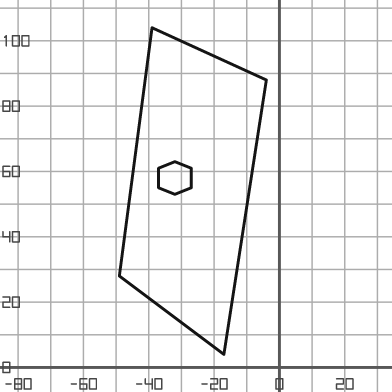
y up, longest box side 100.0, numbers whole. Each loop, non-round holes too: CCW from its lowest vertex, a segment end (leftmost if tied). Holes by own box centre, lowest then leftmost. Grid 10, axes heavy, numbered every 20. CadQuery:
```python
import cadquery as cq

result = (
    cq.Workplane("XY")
    .moveTo(-17.0, 4.0)
    .lineTo(-4.0, 88.0)
    .lineTo(-39.0, 104.0)
    .lineTo(-49.0, 28.0)
    .close()
    .moveTo(-32.0, 53.0)
    .lineTo(-27.0, 55.0)
    .lineTo(-27.0, 61.0)
    .lineTo(-32.0, 63.0)
    .lineTo(-37.0, 61.0)
    .lineTo(-37.0, 55.0)
    .close()
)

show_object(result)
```